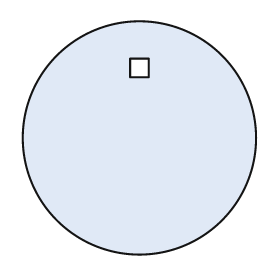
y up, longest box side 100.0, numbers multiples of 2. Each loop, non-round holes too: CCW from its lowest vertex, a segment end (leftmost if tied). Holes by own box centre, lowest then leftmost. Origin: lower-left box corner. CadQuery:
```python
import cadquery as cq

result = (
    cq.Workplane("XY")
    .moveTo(50.0, 50.0)
    .circle(50.0)
    .moveTo(46.0, 76.0)
    .lineTo(54.0, 76.0)
    .lineTo(54.0, 84.0)
    .lineTo(46.0, 84.0)
    .close()
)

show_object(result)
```